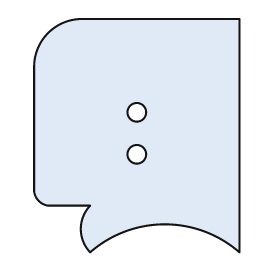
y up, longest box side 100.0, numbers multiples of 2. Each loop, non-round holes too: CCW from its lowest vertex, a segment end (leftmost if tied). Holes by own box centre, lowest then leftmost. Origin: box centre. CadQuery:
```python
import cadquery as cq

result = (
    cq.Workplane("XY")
    .moveTo(-20.0, -50.0)
    .threePointArc((12.0, -38.0), (44.0, -50.0))
    .lineTo(44.0, 50.0)
    .lineTo(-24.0, 50.0)
    .threePointArc((-38.0, 44.0), (-44.0, 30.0))
    .lineTo(-44.0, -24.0)
    .threePointArc((-42.0, -28.0), (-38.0, -30.0))
    .lineTo(-20.0, -30.0)
    .threePointArc((-24.0, -40.0), (-20.0, -50.0))
    .close()
    .moveTo(0.0, -8.0)
    .circle(4.0)
    .moveTo(0.0, 10.0)
    .circle(4.0)
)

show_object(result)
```